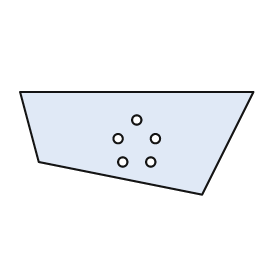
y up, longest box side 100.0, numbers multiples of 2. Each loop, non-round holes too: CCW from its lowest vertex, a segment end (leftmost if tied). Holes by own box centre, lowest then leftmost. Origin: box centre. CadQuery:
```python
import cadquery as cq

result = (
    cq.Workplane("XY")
    .moveTo(28.0, -22.0)
    .lineTo(50.0, 22.0)
    .lineTo(-50.0, 22.0)
    .lineTo(-42.0, -8.0)
    .close()
    .moveTo(-6.0, -8.0)
    .circle(2.0)
    .moveTo(6.0, -8.0)
    .circle(2.0)
    .moveTo(-8.0, 2.0)
    .circle(2.0)
    .moveTo(8.0, 2.0)
    .circle(2.0)
    .moveTo(0.0, 10.0)
    .circle(2.0)
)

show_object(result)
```